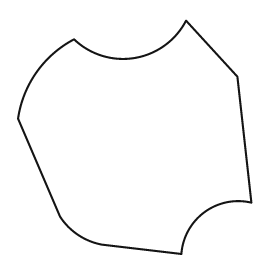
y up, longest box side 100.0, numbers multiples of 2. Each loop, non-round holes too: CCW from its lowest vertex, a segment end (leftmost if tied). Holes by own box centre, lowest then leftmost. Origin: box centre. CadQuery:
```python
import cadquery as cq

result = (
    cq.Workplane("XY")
    .moveTo(20.0, -50.0)
    .threePointArc((30.0, -32.0), (50.0, -28.0))
    .lineTo(44.0, 26.0)
    .lineTo(22.0, 50.0)
    .threePointArc((0.0, 34.0), (-26.0, 42.0))
    .threePointArc((-42.0, 28.0), (-50.0, 8.0))
    .lineTo(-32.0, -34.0)
    .threePointArc((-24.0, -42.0), (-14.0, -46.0))
    .close()
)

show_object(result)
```